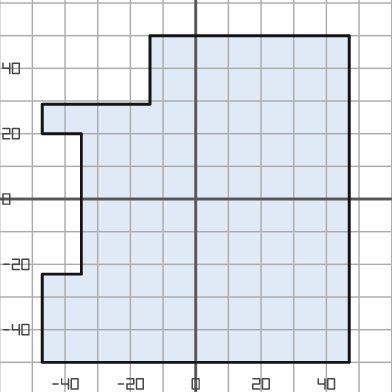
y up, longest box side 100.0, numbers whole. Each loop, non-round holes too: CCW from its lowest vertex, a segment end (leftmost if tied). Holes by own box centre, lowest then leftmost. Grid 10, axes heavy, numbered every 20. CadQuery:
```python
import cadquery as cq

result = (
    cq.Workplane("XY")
    .moveTo(-47.0, -50.0)
    .lineTo(47.0, -50.0)
    .lineTo(47.0, 50.0)
    .lineTo(-14.0, 50.0)
    .lineTo(-14.0, 29.0)
    .lineTo(-47.0, 29.0)
    .lineTo(-47.0, 20.0)
    .lineTo(-35.0, 20.0)
    .lineTo(-35.0, -23.0)
    .lineTo(-47.0, -23.0)
    .close()
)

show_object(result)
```